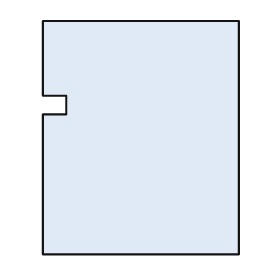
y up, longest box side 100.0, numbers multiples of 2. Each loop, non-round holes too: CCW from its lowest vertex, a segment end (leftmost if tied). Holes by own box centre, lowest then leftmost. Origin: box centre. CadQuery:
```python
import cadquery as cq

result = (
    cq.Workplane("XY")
    .moveTo(-42.0, -50.0)
    .lineTo(42.0, -50.0)
    .lineTo(42.0, 50.0)
    .lineTo(-42.0, 50.0)
    .lineTo(-42.0, 18.0)
    .lineTo(-32.0, 18.0)
    .lineTo(-32.0, 10.0)
    .lineTo(-42.0, 10.0)
    .close()
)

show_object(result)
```